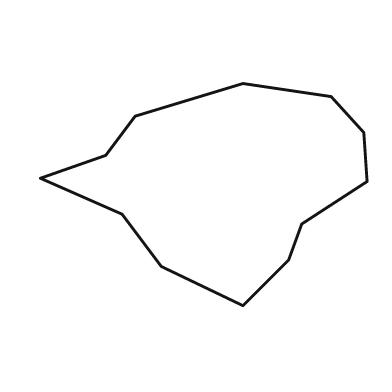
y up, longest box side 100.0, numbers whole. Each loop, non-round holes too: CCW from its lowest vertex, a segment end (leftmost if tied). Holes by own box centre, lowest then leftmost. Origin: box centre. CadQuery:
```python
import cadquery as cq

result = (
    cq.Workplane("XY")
    .moveTo(12.0, -34.0)
    .lineTo(26.0, -20.0)
    .lineTo(30.0, -9.0)
    .lineTo(50.0, 4.0)
    .lineTo(49.0, 19.0)
    .lineTo(39.0, 30.0)
    .lineTo(12.0, 34.0)
    .lineTo(-21.0, 24.0)
    .lineTo(-30.0, 12.0)
    .lineTo(-50.0, 5.0)
    .lineTo(-25.0, -6.0)
    .lineTo(-13.0, -22.0)
    .close()
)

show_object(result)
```